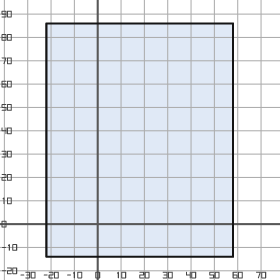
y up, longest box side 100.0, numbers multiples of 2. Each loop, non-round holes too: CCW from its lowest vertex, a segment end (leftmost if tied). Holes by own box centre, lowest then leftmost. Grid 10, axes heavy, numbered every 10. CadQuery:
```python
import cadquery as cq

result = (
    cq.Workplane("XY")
    .moveTo(-22.0, -14.0)
    .lineTo(58.0, -14.0)
    .lineTo(58.0, 86.0)
    .lineTo(-22.0, 86.0)
    .close()
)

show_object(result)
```